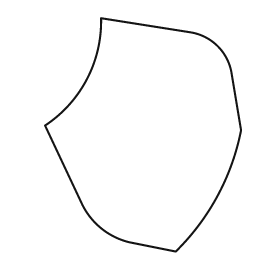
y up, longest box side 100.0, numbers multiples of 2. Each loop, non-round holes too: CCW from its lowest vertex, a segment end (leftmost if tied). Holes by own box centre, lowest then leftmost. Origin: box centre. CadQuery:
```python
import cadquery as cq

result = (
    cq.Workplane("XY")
    .moveTo(14.0, -50.0)
    .threePointArc((32.0, -26.0), (42.0, 2.0))
    .lineTo(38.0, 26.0)
    .threePointArc((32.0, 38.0), (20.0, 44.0))
    .lineTo(-18.0, 50.0)
    .threePointArc((-24.0, 24.0), (-42.0, 4.0))
    .lineTo(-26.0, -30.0)
    .threePointArc((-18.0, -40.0), (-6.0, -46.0))
    .close()
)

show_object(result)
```